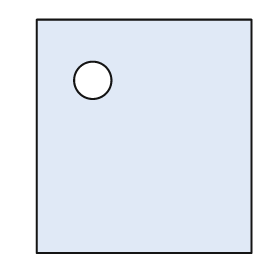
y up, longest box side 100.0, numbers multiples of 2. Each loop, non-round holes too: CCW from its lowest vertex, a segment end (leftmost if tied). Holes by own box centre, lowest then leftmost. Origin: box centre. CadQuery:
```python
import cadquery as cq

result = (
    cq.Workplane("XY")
    .moveTo(-46.0, -50.0)
    .lineTo(46.0, -50.0)
    .lineTo(46.0, 50.0)
    .lineTo(-46.0, 50.0)
    .close()
    .moveTo(-22.0, 24.0)
    .circle(8.0)
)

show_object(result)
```